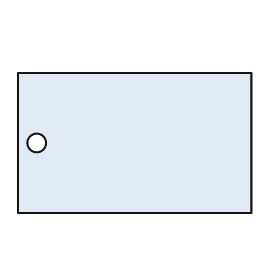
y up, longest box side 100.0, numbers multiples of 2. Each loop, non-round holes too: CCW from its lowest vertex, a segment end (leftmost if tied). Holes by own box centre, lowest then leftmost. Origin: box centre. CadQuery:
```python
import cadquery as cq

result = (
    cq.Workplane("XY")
    .moveTo(-50.0, -30.0)
    .lineTo(50.0, -30.0)
    .lineTo(50.0, 30.0)
    .lineTo(-50.0, 30.0)
    .close()
    .moveTo(-42.0, 0.0)
    .circle(4.0)
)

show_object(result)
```